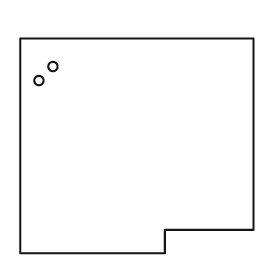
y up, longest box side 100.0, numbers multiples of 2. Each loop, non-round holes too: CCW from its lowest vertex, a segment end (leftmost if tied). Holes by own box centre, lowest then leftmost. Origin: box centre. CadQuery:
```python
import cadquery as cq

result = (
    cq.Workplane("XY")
    .moveTo(-50.0, -46.0)
    .lineTo(12.0, -46.0)
    .lineTo(12.0, -36.0)
    .lineTo(50.0, -36.0)
    .lineTo(50.0, 46.0)
    .lineTo(-50.0, 46.0)
    .close()
    .moveTo(-42.0, 28.0)
    .circle(2.0)
    .moveTo(-36.0, 34.0)
    .circle(2.0)
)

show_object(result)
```